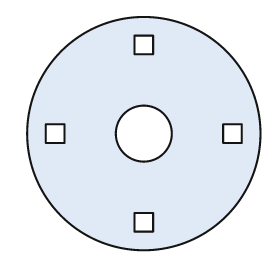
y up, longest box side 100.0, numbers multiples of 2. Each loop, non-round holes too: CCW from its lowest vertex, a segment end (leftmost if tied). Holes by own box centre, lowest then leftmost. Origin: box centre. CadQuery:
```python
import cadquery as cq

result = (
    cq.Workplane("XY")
    .moveTo(0.0, 0.0)
    .circle(50.0)
    .moveTo(-4.0, -42.0)
    .lineTo(4.0, -42.0)
    .lineTo(4.0, -34.0)
    .lineTo(-4.0, -34.0)
    .close()
    .moveTo(-42.0, -4.0)
    .lineTo(-34.0, -4.0)
    .lineTo(-34.0, 4.0)
    .lineTo(-42.0, 4.0)
    .close()
    .moveTo(0.0, 0.0)
    .circle(12.0)
    .moveTo(34.0, -4.0)
    .lineTo(42.0, -4.0)
    .lineTo(42.0, 4.0)
    .lineTo(34.0, 4.0)
    .close()
    .moveTo(-4.0, 34.0)
    .lineTo(4.0, 34.0)
    .lineTo(4.0, 42.0)
    .lineTo(-4.0, 42.0)
    .close()
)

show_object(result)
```